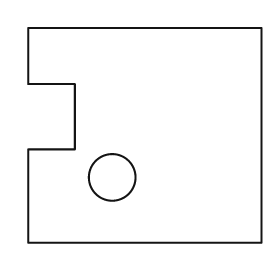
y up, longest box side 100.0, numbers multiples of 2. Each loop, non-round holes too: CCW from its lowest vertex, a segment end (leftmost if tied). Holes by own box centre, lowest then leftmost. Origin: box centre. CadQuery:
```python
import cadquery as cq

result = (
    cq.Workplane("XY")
    .moveTo(-50.0, -46.0)
    .lineTo(50.0, -46.0)
    .lineTo(50.0, 46.0)
    .lineTo(-50.0, 46.0)
    .lineTo(-50.0, 22.0)
    .lineTo(-30.0, 22.0)
    .lineTo(-30.0, -6.0)
    .lineTo(-50.0, -6.0)
    .close()
    .moveTo(-14.0, -18.0)
    .circle(10.0)
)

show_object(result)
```